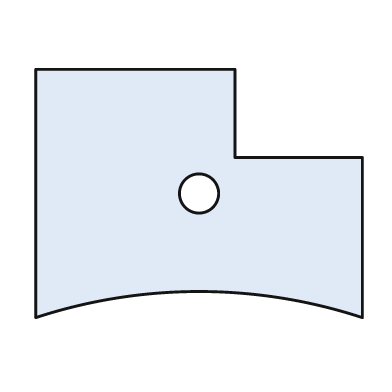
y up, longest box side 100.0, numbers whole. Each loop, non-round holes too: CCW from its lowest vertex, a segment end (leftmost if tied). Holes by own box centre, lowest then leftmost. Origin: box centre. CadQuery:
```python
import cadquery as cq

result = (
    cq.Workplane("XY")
    .moveTo(-50.0, -38.0)
    .threePointArc((0.0, -30.0), (50.0, -38.0))
    .lineTo(50.0, 11.0)
    .lineTo(11.0, 11.0)
    .lineTo(11.0, 38.0)
    .lineTo(-50.0, 38.0)
    .close()
    .moveTo(0.0, 0.0)
    .circle(6.0)
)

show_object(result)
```